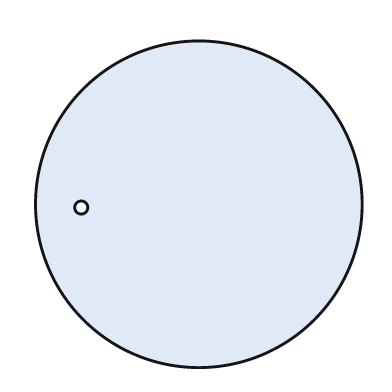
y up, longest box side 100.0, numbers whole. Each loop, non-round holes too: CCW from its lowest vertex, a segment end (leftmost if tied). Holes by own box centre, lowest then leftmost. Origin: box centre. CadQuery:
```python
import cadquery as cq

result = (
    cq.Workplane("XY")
    .moveTo(0.0, 0.0)
    .circle(50.0)
    .moveTo(-36.0, -1.0)
    .circle(2.0)
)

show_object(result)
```